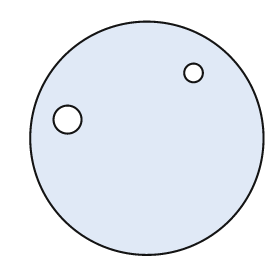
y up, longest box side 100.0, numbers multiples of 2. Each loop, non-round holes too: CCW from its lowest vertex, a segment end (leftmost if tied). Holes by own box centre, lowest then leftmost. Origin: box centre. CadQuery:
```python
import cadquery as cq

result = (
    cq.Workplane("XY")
    .moveTo(0.0, 0.0)
    .circle(50.0)
    .moveTo(-34.0, 8.0)
    .circle(6.0)
    .moveTo(20.0, 28.0)
    .circle(4.0)
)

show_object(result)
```